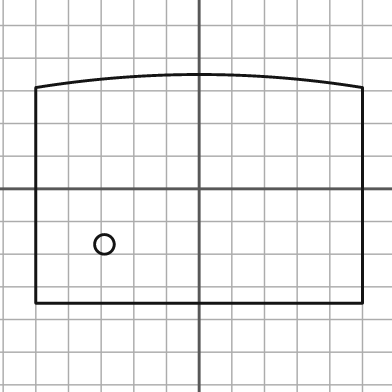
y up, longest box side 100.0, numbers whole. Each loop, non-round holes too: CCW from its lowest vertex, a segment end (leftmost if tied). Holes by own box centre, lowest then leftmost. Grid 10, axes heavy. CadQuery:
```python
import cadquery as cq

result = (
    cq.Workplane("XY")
    .moveTo(-50.0, -35.0)
    .lineTo(50.0, -35.0)
    .lineTo(50.0, 31.0)
    .threePointArc((0.0, 35.0), (-50.0, 31.0))
    .close()
    .moveTo(-29.0, -17.0)
    .circle(3.0)
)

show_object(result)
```